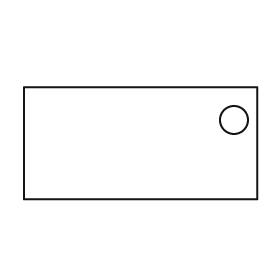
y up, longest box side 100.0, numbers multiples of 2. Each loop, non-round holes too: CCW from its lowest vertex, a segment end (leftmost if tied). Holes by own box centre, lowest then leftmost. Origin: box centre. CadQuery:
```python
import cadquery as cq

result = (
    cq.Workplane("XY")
    .moveTo(-50.0, -24.0)
    .lineTo(50.0, -24.0)
    .lineTo(50.0, 24.0)
    .lineTo(-50.0, 24.0)
    .close()
    .moveTo(40.0, 10.0)
    .circle(6.0)
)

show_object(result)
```